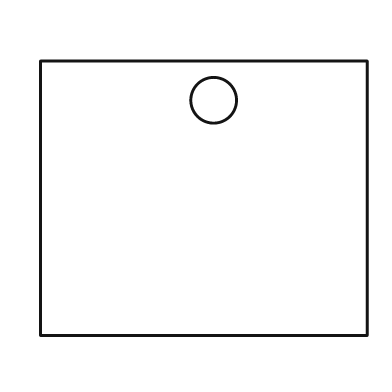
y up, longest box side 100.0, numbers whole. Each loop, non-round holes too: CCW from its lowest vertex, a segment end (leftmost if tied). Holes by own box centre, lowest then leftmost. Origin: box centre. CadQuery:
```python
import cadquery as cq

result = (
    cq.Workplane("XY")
    .moveTo(-50.0, -42.0)
    .lineTo(50.0, -42.0)
    .lineTo(50.0, 42.0)
    .lineTo(-50.0, 42.0)
    .close()
    .moveTo(3.0, 30.0)
    .circle(7.0)
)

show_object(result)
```